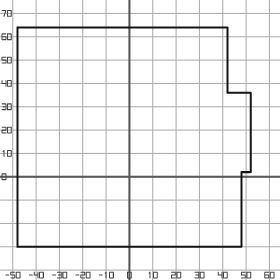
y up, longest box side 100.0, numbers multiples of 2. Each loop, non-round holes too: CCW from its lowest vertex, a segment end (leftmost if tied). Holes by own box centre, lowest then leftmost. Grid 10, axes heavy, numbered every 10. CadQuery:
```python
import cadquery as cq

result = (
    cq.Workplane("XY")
    .moveTo(-48.0, -30.0)
    .lineTo(48.0, -30.0)
    .lineTo(48.0, 2.0)
    .lineTo(52.0, 2.0)
    .lineTo(52.0, 36.0)
    .lineTo(42.0, 36.0)
    .lineTo(42.0, 64.0)
    .lineTo(-48.0, 64.0)
    .close()
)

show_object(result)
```